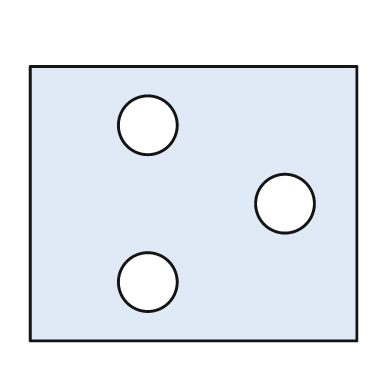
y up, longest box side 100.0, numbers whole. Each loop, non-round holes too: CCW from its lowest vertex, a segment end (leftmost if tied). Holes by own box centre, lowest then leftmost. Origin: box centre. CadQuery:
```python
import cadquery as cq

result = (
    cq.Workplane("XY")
    .moveTo(-50.0, -42.0)
    .lineTo(50.0, -42.0)
    .lineTo(50.0, 42.0)
    .lineTo(-50.0, 42.0)
    .close()
    .moveTo(-14.0, -24.0)
    .circle(9.0)
    .moveTo(28.0, 0.0)
    .circle(9.0)
    .moveTo(-14.0, 24.0)
    .circle(9.0)
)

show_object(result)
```